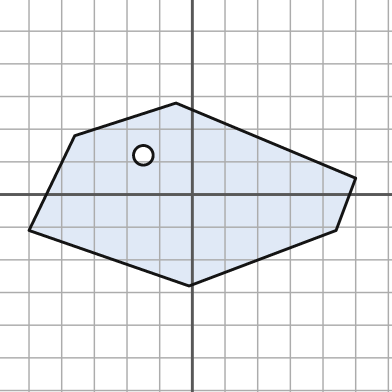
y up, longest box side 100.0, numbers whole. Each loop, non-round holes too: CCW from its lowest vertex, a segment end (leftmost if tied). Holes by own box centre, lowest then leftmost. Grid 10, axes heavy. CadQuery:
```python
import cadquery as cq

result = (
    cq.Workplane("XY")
    .moveTo(-1.0, -28.0)
    .lineTo(44.0, -11.0)
    .lineTo(50.0, 5.0)
    .lineTo(-5.0, 28.0)
    .lineTo(-36.0, 18.0)
    .lineTo(-50.0, -11.0)
    .close()
    .moveTo(-15.0, 12.0)
    .circle(3.0)
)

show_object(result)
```